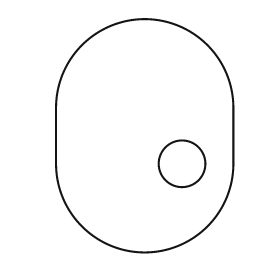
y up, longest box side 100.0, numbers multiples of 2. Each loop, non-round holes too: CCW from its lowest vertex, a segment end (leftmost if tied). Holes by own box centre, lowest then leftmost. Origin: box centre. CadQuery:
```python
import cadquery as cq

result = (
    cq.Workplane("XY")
    .moveTo(-38.0, -12.0)
    .threePointArc((0.0, -50.0), (38.0, -12.0))
    .lineTo(38.0, 12.0)
    .threePointArc((0.0, 50.0), (-38.0, 12.0))
    .close()
    .moveTo(16.0, -12.0)
    .circle(10.0)
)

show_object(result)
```